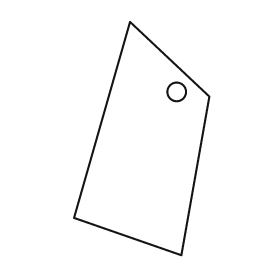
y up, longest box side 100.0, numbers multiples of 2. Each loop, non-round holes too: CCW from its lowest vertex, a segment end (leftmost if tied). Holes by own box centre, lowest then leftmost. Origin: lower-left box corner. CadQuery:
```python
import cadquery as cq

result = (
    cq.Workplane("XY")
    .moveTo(46.0, 0.0)
    .lineTo(58.0, 68.0)
    .lineTo(24.0, 100.0)
    .lineTo(0.0, 16.0)
    .close()
    .moveTo(44.0, 70.0)
    .circle(4.0)
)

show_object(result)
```